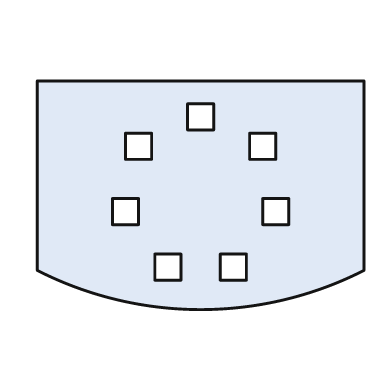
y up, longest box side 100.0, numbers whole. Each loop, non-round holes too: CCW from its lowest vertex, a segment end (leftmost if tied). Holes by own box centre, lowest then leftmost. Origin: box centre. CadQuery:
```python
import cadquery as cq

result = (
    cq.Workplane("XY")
    .moveTo(-50.0, -23.0)
    .threePointArc((0.0, -35.0), (50.0, -23.0))
    .lineTo(50.0, 35.0)
    .lineTo(-50.0, 35.0)
    .close()
    .moveTo(-14.0, -26.0)
    .lineTo(-6.0, -26.0)
    .lineTo(-6.0, -18.0)
    .lineTo(-14.0, -18.0)
    .close()
    .moveTo(6.0, -26.0)
    .lineTo(14.0, -26.0)
    .lineTo(14.0, -18.0)
    .lineTo(6.0, -18.0)
    .close()
    .moveTo(-27.0, -9.0)
    .lineTo(-19.0, -9.0)
    .lineTo(-19.0, -1.0)
    .lineTo(-27.0, -1.0)
    .close()
    .moveTo(19.0, -9.0)
    .lineTo(27.0, -9.0)
    .lineTo(27.0, -1.0)
    .lineTo(19.0, -1.0)
    .close()
    .moveTo(-23.0, 11.0)
    .lineTo(-15.0, 11.0)
    .lineTo(-15.0, 19.0)
    .lineTo(-23.0, 19.0)
    .close()
    .moveTo(15.0, 11.0)
    .lineTo(23.0, 11.0)
    .lineTo(23.0, 19.0)
    .lineTo(15.0, 19.0)
    .close()
    .moveTo(-4.0, 20.0)
    .lineTo(4.0, 20.0)
    .lineTo(4.0, 28.0)
    .lineTo(-4.0, 28.0)
    .close()
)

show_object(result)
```